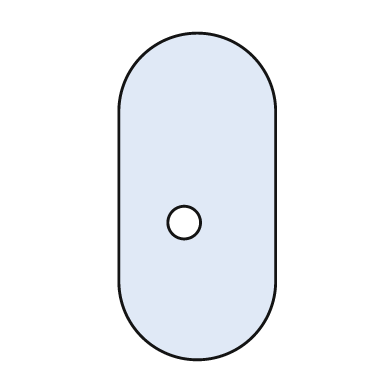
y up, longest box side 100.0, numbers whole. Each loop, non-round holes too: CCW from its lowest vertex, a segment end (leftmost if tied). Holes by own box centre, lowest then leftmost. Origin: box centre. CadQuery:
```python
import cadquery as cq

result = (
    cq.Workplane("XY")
    .moveTo(-24.0, -26.0)
    .threePointArc((0.0, -50.0), (24.0, -26.0))
    .lineTo(24.0, 26.0)
    .threePointArc((0.0, 50.0), (-24.0, 26.0))
    .close()
    .moveTo(-4.0, -8.0)
    .circle(5.0)
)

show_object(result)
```